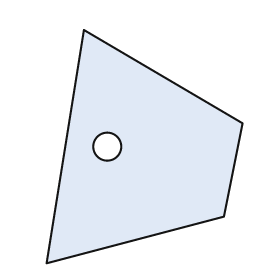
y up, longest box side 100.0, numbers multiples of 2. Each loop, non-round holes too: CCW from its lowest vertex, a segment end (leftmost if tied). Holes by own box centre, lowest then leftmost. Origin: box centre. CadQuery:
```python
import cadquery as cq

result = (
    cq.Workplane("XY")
    .moveTo(-42.0, -50.0)
    .lineTo(34.0, -30.0)
    .lineTo(42.0, 10.0)
    .lineTo(-26.0, 50.0)
    .close()
    .moveTo(-16.0, 0.0)
    .circle(6.0)
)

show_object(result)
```